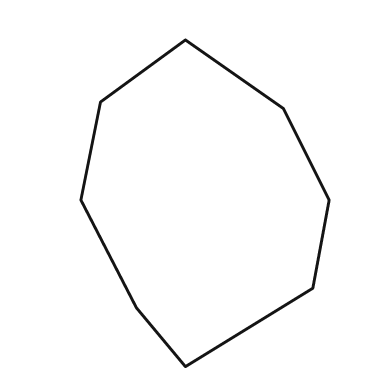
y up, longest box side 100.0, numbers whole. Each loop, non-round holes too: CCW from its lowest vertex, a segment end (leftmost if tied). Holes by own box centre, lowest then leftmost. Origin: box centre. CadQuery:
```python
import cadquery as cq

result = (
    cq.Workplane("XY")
    .moveTo(-6.0, -50.0)
    .lineTo(33.0, -26.0)
    .lineTo(38.0, 1.0)
    .lineTo(24.0, 29.0)
    .lineTo(-6.0, 50.0)
    .lineTo(-32.0, 31.0)
    .lineTo(-38.0, 1.0)
    .lineTo(-21.0, -32.0)
    .close()
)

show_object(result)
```